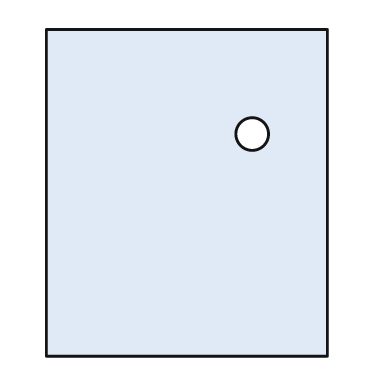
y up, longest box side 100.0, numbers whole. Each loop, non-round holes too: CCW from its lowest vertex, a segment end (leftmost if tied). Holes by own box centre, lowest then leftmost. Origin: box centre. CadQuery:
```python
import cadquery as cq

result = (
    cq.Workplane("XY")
    .moveTo(-43.0, -50.0)
    .lineTo(43.0, -50.0)
    .lineTo(43.0, 50.0)
    .lineTo(-43.0, 50.0)
    .close()
    .moveTo(20.0, 18.0)
    .circle(5.0)
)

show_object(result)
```